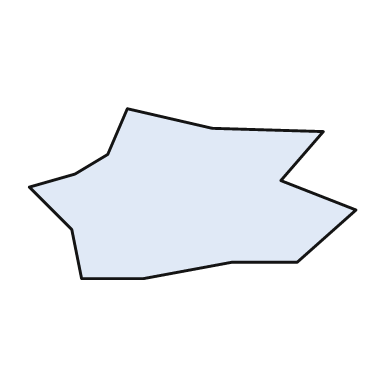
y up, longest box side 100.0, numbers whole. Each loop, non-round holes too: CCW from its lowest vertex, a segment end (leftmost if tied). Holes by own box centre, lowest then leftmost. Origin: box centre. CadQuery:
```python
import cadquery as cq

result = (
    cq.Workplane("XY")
    .moveTo(-34.0, -26.0)
    .lineTo(-15.0, -26.0)
    .lineTo(12.0, -21.0)
    .lineTo(32.0, -21.0)
    .lineTo(50.0, -5.0)
    .lineTo(27.0, 4.0)
    .lineTo(40.0, 19.0)
    .lineTo(6.0, 20.0)
    .lineTo(-20.0, 26.0)
    .lineTo(-26.0, 12.0)
    .lineTo(-36.0, 6.0)
    .lineTo(-50.0, 2.0)
    .lineTo(-37.0, -11.0)
    .close()
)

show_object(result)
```